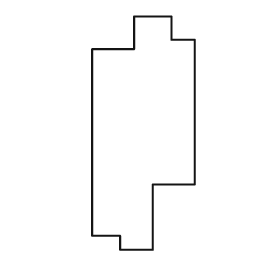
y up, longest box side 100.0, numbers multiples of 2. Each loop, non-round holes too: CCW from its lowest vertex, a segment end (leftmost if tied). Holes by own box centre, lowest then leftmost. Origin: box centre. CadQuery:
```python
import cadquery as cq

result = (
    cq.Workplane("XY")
    .moveTo(-10.0, -50.0)
    .lineTo(4.0, -50.0)
    .lineTo(4.0, -22.0)
    .lineTo(22.0, -22.0)
    .lineTo(22.0, 40.0)
    .lineTo(12.0, 40.0)
    .lineTo(12.0, 50.0)
    .lineTo(-4.0, 50.0)
    .lineTo(-4.0, 36.0)
    .lineTo(-22.0, 36.0)
    .lineTo(-22.0, -44.0)
    .lineTo(-10.0, -44.0)
    .close()
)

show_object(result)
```